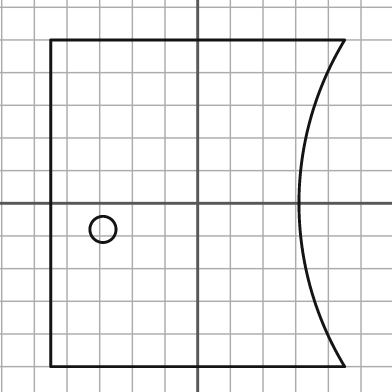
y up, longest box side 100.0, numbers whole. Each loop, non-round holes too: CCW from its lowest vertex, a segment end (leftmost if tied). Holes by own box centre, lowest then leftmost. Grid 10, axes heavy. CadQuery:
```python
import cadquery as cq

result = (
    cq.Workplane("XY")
    .moveTo(-45.0, -50.0)
    .lineTo(45.0, -50.0)
    .threePointArc((31.0, 0.0), (45.0, 50.0))
    .lineTo(-45.0, 50.0)
    .close()
    .moveTo(-29.0, -8.0)
    .circle(4.0)
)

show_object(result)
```